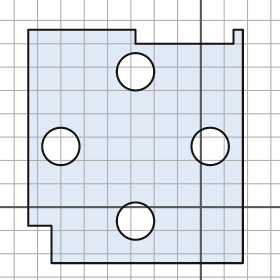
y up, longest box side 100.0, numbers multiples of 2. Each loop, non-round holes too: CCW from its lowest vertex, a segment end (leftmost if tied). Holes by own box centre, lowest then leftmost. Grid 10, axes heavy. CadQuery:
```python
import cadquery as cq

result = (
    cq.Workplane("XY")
    .moveTo(-64.0, -24.0)
    .lineTo(18.0, -24.0)
    .lineTo(18.0, 76.0)
    .lineTo(14.0, 76.0)
    .lineTo(14.0, 70.0)
    .lineTo(-28.0, 70.0)
    .lineTo(-28.0, 76.0)
    .lineTo(-74.0, 76.0)
    .lineTo(-74.0, -8.0)
    .lineTo(-64.0, -8.0)
    .close()
    .moveTo(-28.0, -6.0)
    .circle(8.0)
    .moveTo(-60.0, 26.0)
    .circle(8.0)
    .moveTo(4.0, 26.0)
    .circle(8.0)
    .moveTo(-28.0, 58.0)
    .circle(8.0)
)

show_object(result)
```